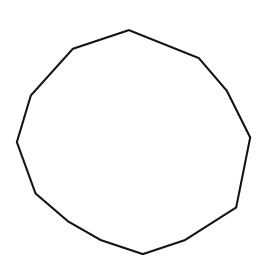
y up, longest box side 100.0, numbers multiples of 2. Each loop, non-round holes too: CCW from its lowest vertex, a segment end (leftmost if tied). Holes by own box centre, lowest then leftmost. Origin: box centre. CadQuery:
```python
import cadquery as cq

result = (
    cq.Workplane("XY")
    .moveTo(4.0, -48.0)
    .lineTo(22.0, -42.0)
    .lineTo(44.0, -28.0)
    .lineTo(50.0, 2.0)
    .lineTo(40.0, 22.0)
    .lineTo(28.0, 36.0)
    .lineTo(-2.0, 48.0)
    .lineTo(-26.0, 40.0)
    .lineTo(-44.0, 20.0)
    .lineTo(-50.0, 0.0)
    .lineTo(-42.0, -22.0)
    .lineTo(-28.0, -34.0)
    .lineTo(-14.0, -42.0)
    .close()
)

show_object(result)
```